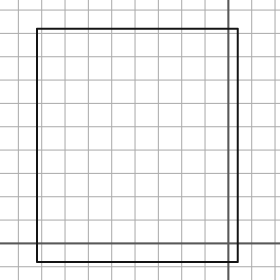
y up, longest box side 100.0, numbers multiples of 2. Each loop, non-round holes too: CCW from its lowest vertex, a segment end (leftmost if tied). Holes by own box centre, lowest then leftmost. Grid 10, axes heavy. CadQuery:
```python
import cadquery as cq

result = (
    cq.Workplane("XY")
    .moveTo(-82.0, -8.0)
    .lineTo(4.0, -8.0)
    .lineTo(4.0, 92.0)
    .lineTo(-82.0, 92.0)
    .close()
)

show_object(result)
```